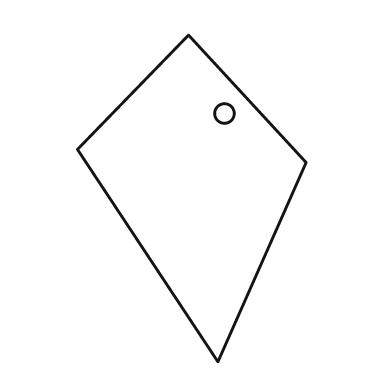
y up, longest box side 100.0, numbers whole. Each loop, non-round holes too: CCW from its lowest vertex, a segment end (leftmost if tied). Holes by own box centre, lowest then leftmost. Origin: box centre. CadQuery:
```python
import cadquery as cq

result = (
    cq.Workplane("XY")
    .moveTo(8.0, -50.0)
    .lineTo(35.0, 11.0)
    .lineTo(-1.0, 50.0)
    .lineTo(-35.0, 15.0)
    .close()
    .moveTo(10.0, 26.0)
    .circle(3.0)
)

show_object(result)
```